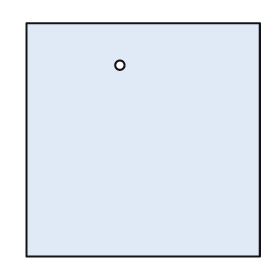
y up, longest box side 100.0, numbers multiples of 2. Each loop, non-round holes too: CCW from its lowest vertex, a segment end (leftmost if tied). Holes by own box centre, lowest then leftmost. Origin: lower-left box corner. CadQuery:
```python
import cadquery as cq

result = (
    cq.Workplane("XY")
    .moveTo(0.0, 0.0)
    .lineTo(100.0, 0.0)
    .lineTo(100.0, 100.0)
    .lineTo(0.0, 100.0)
    .close()
    .moveTo(40.0, 82.0)
    .circle(2.0)
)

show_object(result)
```